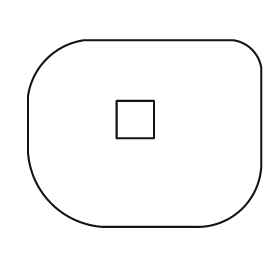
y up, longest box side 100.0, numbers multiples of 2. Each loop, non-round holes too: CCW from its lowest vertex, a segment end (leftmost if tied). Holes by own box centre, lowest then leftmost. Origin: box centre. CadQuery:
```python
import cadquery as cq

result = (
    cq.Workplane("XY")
    .moveTo(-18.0, -40.0)
    .lineTo(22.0, -40.0)
    .threePointArc((42.0, -32.0), (50.0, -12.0))
    .lineTo(50.0, 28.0)
    .threePointArc((46.0, 36.0), (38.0, 40.0))
    .lineTo(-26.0, 40.0)
    .threePointArc((-42.0, 32.0), (-50.0, 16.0))
    .lineTo(-50.0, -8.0)
    .threePointArc((-40.0, -30.0), (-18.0, -40.0))
    .close()
    .moveTo(-12.0, -2.0)
    .lineTo(4.0, -2.0)
    .lineTo(4.0, 14.0)
    .lineTo(-12.0, 14.0)
    .close()
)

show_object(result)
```